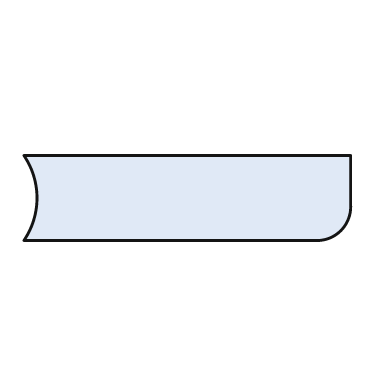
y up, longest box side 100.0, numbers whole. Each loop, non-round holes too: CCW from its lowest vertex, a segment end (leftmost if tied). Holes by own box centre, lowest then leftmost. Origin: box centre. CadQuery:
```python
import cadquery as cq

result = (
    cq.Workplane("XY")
    .moveTo(-50.0, -13.0)
    .lineTo(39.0, -13.0)
    .threePointArc((47.0, -10.0), (50.0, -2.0))
    .lineTo(50.0, 13.0)
    .lineTo(-50.0, 13.0)
    .threePointArc((-46.0, 0.0), (-50.0, -13.0))
    .close()
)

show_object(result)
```